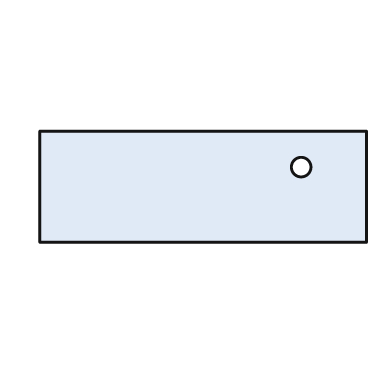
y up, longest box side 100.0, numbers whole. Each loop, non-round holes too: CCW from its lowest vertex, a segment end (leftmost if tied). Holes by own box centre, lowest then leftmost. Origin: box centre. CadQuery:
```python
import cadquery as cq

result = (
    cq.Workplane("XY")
    .moveTo(-50.0, -17.0)
    .lineTo(50.0, -17.0)
    .lineTo(50.0, 17.0)
    .lineTo(-50.0, 17.0)
    .close()
    .moveTo(30.0, 6.0)
    .circle(3.0)
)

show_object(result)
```